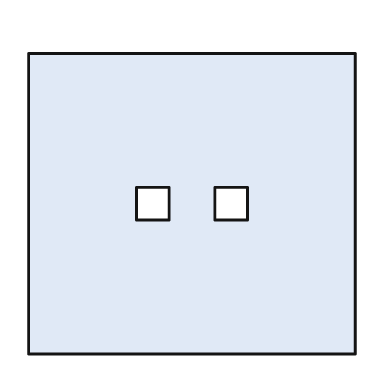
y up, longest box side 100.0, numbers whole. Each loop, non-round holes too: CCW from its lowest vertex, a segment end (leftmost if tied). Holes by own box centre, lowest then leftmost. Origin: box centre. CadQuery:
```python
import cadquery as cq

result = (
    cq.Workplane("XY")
    .moveTo(-50.0, -46.0)
    .lineTo(50.0, -46.0)
    .lineTo(50.0, 46.0)
    .lineTo(-50.0, 46.0)
    .close()
    .moveTo(-17.0, -5.0)
    .lineTo(-7.0, -5.0)
    .lineTo(-7.0, 5.0)
    .lineTo(-17.0, 5.0)
    .close()
    .moveTo(7.0, -5.0)
    .lineTo(17.0, -5.0)
    .lineTo(17.0, 5.0)
    .lineTo(7.0, 5.0)
    .close()
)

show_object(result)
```